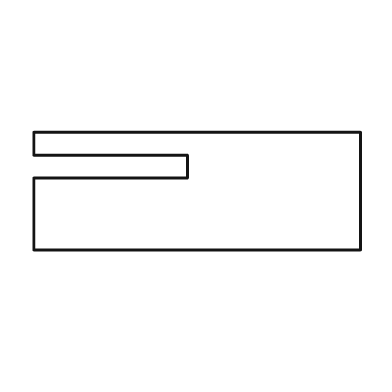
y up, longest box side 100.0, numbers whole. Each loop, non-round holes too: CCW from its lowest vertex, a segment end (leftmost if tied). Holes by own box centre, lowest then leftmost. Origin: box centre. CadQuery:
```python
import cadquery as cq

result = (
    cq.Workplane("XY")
    .moveTo(-50.0, -18.0)
    .lineTo(50.0, -18.0)
    .lineTo(50.0, 18.0)
    .lineTo(-50.0, 18.0)
    .lineTo(-50.0, 11.0)
    .lineTo(-3.0, 11.0)
    .lineTo(-3.0, 4.0)
    .lineTo(-50.0, 4.0)
    .close()
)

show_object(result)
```